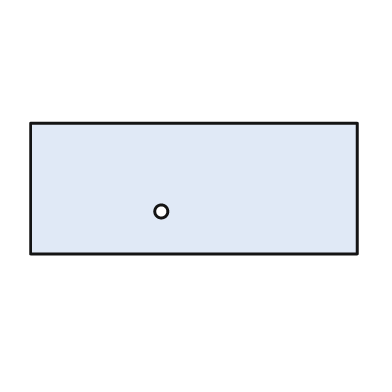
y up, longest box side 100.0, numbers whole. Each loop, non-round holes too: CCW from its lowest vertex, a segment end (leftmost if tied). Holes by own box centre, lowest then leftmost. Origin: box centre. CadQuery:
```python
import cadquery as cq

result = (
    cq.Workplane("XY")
    .moveTo(-50.0, -20.0)
    .lineTo(50.0, -20.0)
    .lineTo(50.0, 20.0)
    .lineTo(-50.0, 20.0)
    .close()
    .moveTo(-10.0, -7.0)
    .circle(2.0)
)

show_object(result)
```